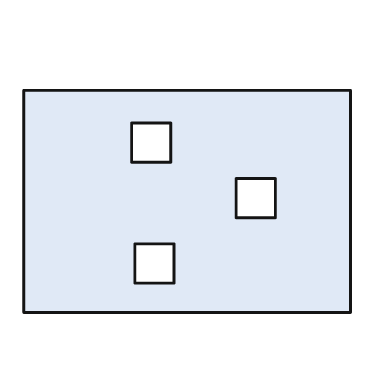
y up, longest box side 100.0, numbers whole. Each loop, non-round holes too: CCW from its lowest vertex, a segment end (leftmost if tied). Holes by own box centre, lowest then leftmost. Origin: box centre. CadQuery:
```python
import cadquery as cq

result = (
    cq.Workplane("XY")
    .moveTo(-50.0, -34.0)
    .lineTo(50.0, -34.0)
    .lineTo(50.0, 34.0)
    .lineTo(-50.0, 34.0)
    .close()
    .moveTo(-16.0, -25.0)
    .lineTo(-4.0, -25.0)
    .lineTo(-4.0, -13.0)
    .lineTo(-16.0, -13.0)
    .close()
    .moveTo(15.0, -5.0)
    .lineTo(27.0, -5.0)
    .lineTo(27.0, 7.0)
    .lineTo(15.0, 7.0)
    .close()
    .moveTo(-17.0, 12.0)
    .lineTo(-5.0, 12.0)
    .lineTo(-5.0, 24.0)
    .lineTo(-17.0, 24.0)
    .close()
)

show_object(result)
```